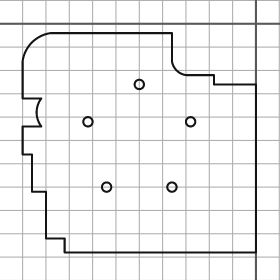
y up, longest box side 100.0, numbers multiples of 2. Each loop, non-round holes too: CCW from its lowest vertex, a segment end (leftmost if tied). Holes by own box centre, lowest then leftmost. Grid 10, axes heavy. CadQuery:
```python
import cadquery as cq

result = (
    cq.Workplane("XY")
    .moveTo(-82.0, -98.0)
    .lineTo(0.0, -98.0)
    .lineTo(0.0, -26.0)
    .lineTo(-18.0, -26.0)
    .lineTo(-18.0, -22.0)
    .lineTo(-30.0, -22.0)
    .threePointArc((-34.0, -20.0), (-36.0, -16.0))
    .lineTo(-36.0, -4.0)
    .lineTo(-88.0, -4.0)
    .threePointArc((-96.0, -8.0), (-100.0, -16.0))
    .lineTo(-100.0, -32.0)
    .lineTo(-92.0, -32.0)
    .threePointArc((-94.0, -38.0), (-92.0, -44.0))
    .lineTo(-100.0, -44.0)
    .lineTo(-100.0, -56.0)
    .lineTo(-96.0, -56.0)
    .lineTo(-96.0, -72.0)
    .lineTo(-90.0, -72.0)
    .lineTo(-90.0, -92.0)
    .lineTo(-82.0, -92.0)
    .close()
    .moveTo(-64.0, -70.0)
    .circle(2.0)
    .moveTo(-36.0, -70.0)
    .circle(2.0)
    .moveTo(-72.0, -42.0)
    .circle(2.0)
    .moveTo(-28.0, -42.0)
    .circle(2.0)
    .moveTo(-50.0, -26.0)
    .circle(2.0)
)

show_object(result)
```